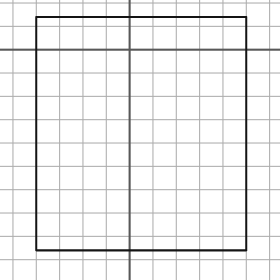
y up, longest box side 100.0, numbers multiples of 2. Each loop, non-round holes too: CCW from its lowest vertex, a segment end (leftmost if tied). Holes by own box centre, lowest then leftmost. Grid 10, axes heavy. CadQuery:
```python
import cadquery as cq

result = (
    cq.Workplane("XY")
    .moveTo(-40.0, -86.0)
    .lineTo(50.0, -86.0)
    .lineTo(50.0, 14.0)
    .lineTo(-40.0, 14.0)
    .close()
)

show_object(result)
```